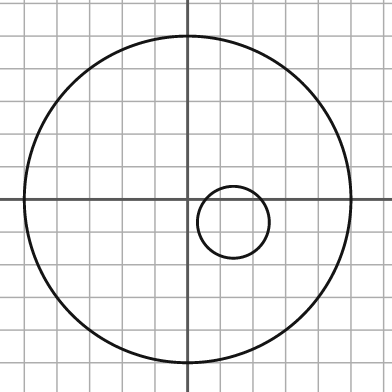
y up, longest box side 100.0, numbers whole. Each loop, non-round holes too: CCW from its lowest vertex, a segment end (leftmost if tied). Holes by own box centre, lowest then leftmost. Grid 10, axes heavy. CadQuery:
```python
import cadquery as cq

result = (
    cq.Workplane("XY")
    .moveTo(0.0, 0.0)
    .circle(50.0)
    .moveTo(14.0, -7.0)
    .circle(11.0)
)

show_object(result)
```